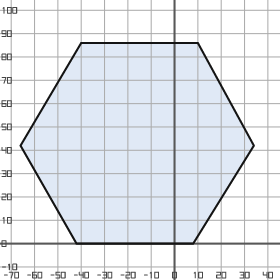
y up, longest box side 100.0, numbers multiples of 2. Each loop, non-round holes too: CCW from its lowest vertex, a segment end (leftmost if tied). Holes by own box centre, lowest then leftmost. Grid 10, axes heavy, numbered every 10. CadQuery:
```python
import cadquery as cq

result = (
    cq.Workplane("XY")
    .moveTo(-42.0, 0.0)
    .lineTo(8.0, 0.0)
    .lineTo(34.0, 42.0)
    .lineTo(10.0, 86.0)
    .lineTo(-40.0, 86.0)
    .lineTo(-66.0, 42.0)
    .close()
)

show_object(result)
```